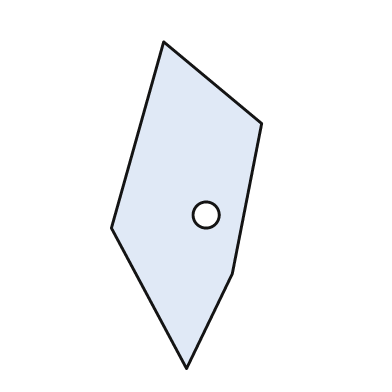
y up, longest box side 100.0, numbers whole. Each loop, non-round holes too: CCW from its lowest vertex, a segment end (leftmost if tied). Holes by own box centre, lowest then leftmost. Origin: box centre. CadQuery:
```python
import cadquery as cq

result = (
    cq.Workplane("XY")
    .moveTo(0.0, -50.0)
    .lineTo(14.0, -21.0)
    .lineTo(23.0, 25.0)
    .lineTo(-7.0, 50.0)
    .lineTo(-23.0, -7.0)
    .close()
    .moveTo(6.0, -3.0)
    .circle(4.0)
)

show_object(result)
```